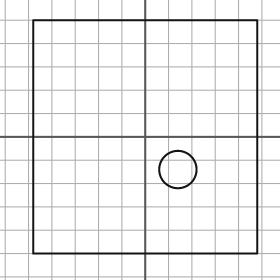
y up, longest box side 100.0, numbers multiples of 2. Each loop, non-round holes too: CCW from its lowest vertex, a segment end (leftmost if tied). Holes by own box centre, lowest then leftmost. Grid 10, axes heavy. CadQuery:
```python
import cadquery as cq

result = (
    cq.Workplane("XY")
    .moveTo(-48.0, -50.0)
    .lineTo(48.0, -50.0)
    .lineTo(48.0, 50.0)
    .lineTo(-48.0, 50.0)
    .close()
    .moveTo(14.0, -14.0)
    .circle(8.0)
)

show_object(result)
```